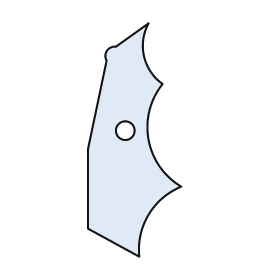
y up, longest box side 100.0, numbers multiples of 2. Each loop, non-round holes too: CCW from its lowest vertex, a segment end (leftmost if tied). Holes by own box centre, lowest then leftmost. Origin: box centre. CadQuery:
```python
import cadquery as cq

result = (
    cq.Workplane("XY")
    .moveTo(2.0, -50.0)
    .threePointArc((6.0, -32.0), (20.0, -20.0))
    .threePointArc((6.0, 0.0), (12.0, 24.0))
    .threePointArc((4.0, 36.0), (6.0, 50.0))
    .lineTo(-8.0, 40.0)
    .threePointArc((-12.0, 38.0), (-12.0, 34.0))
    .lineTo(-20.0, -4.0)
    .lineTo(-20.0, -38.0)
    .close()
    .moveTo(-4.0, 4.0)
    .circle(4.0)
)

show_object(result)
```